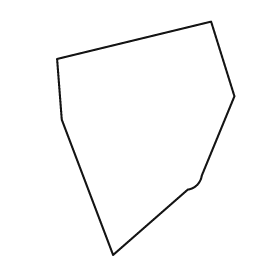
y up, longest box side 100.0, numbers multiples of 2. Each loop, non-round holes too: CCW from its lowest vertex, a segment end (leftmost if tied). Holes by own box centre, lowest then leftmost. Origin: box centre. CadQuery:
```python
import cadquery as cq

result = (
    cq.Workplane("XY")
    .moveTo(-14.0, -50.0)
    .lineTo(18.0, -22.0)
    .threePointArc((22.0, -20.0), (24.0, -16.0))
    .lineTo(38.0, 18.0)
    .lineTo(28.0, 50.0)
    .lineTo(-38.0, 34.0)
    .lineTo(-36.0, 8.0)
    .close()
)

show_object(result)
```